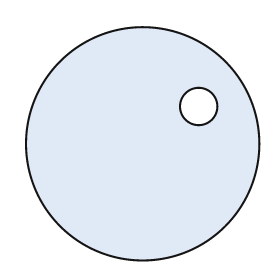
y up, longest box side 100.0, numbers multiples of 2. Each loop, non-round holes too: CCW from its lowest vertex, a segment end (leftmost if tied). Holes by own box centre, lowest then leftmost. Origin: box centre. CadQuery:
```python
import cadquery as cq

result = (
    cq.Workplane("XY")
    .moveTo(0.0, 0.0)
    .circle(50.0)
    .moveTo(24.0, 16.0)
    .circle(8.0)
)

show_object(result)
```